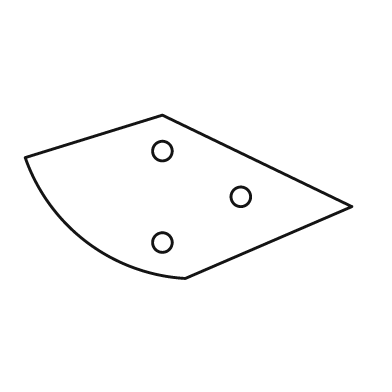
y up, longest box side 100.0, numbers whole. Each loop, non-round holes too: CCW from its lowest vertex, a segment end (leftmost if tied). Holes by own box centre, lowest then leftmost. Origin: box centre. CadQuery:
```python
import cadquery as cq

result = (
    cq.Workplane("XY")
    .moveTo(-1.0, -25.0)
    .lineTo(50.0, -3.0)
    .lineTo(-8.0, 25.0)
    .lineTo(-50.0, 12.0)
    .threePointArc((-31.0, -14.0), (-1.0, -25.0))
    .close()
    .moveTo(-8.0, -14.0)
    .circle(3.0)
    .moveTo(16.0, 0.0)
    .circle(3.0)
    .moveTo(-8.0, 14.0)
    .circle(3.0)
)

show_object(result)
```